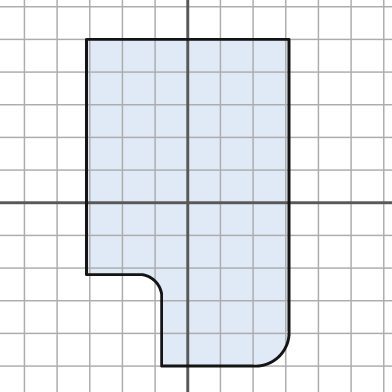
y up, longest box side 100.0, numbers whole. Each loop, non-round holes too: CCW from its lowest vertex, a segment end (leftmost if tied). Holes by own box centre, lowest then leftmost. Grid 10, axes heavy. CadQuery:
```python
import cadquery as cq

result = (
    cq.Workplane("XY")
    .moveTo(-8.0, -50.0)
    .lineTo(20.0, -50.0)
    .threePointArc((28.0, -47.0), (31.0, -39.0))
    .lineTo(31.0, 50.0)
    .lineTo(-31.0, 50.0)
    .lineTo(-31.0, -22.0)
    .lineTo(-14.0, -22.0)
    .threePointArc((-10.0, -24.0), (-8.0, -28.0))
    .close()
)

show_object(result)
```